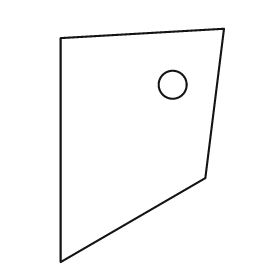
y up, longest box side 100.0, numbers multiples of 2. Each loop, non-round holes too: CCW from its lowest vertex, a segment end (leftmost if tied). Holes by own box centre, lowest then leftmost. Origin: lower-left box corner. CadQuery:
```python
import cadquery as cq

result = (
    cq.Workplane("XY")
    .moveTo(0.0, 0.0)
    .lineTo(62.0, 36.0)
    .lineTo(70.0, 100.0)
    .lineTo(0.0, 96.0)
    .close()
    .moveTo(48.0, 76.0)
    .circle(6.0)
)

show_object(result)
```